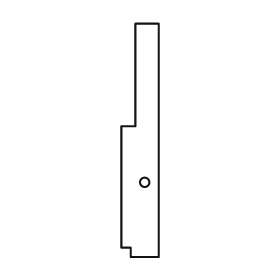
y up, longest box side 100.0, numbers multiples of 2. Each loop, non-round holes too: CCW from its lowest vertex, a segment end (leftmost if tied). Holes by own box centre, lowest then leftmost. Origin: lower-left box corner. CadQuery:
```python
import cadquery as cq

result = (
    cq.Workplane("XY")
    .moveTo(4.0, 0.0)
    .lineTo(16.0, 0.0)
    .lineTo(16.0, 100.0)
    .lineTo(6.0, 100.0)
    .lineTo(6.0, 56.0)
    .lineTo(0.0, 56.0)
    .lineTo(0.0, 4.0)
    .lineTo(4.0, 4.0)
    .close()
    .moveTo(10.0, 32.0)
    .circle(2.0)
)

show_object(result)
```